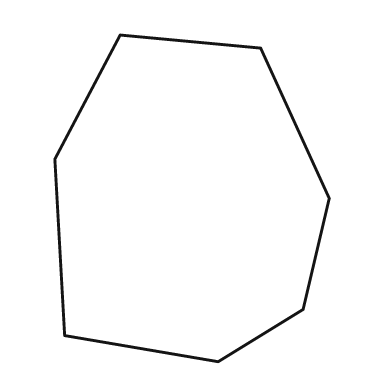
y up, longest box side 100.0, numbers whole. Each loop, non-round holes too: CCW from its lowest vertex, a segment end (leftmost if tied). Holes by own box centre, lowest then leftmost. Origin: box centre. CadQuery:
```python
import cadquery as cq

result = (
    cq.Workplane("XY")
    .moveTo(8.0, -50.0)
    .lineTo(34.0, -34.0)
    .lineTo(42.0, 0.0)
    .lineTo(21.0, 46.0)
    .lineTo(-22.0, 50.0)
    .lineTo(-42.0, 12.0)
    .lineTo(-39.0, -42.0)
    .close()
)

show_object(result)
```